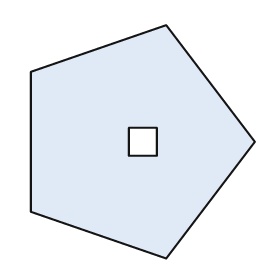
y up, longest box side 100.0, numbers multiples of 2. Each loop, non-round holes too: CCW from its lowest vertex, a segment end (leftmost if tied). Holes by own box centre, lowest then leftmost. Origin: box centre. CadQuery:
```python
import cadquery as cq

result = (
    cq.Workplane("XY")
    .moveTo(10.0, -50.0)
    .lineTo(48.0, 0.0)
    .lineTo(10.0, 50.0)
    .lineTo(-48.0, 30.0)
    .lineTo(-48.0, -30.0)
    .close()
    .moveTo(-6.0, -6.0)
    .lineTo(6.0, -6.0)
    .lineTo(6.0, 6.0)
    .lineTo(-6.0, 6.0)
    .close()
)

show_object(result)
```